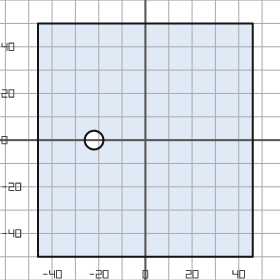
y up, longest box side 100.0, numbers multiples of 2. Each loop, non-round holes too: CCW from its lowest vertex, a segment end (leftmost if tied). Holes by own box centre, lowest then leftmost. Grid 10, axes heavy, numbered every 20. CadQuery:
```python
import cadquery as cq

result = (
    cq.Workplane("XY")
    .moveTo(-46.0, -50.0)
    .lineTo(46.0, -50.0)
    .lineTo(46.0, 50.0)
    .lineTo(-46.0, 50.0)
    .close()
    .moveTo(-22.0, 0.0)
    .circle(4.0)
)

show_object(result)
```